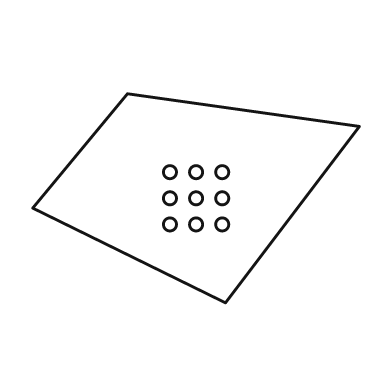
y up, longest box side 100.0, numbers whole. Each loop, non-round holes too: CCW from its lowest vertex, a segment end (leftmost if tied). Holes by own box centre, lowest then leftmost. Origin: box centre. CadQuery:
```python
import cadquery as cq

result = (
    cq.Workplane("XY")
    .moveTo(9.0, -32.0)
    .lineTo(50.0, 22.0)
    .lineTo(-21.0, 32.0)
    .lineTo(-50.0, -3.0)
    .close()
    .moveTo(-8.0, -8.0)
    .circle(2.0)
    .moveTo(0.0, -8.0)
    .circle(2.0)
    .moveTo(8.0, -8.0)
    .circle(2.0)
    .moveTo(-8.0, 0.0)
    .circle(2.0)
    .moveTo(0.0, 0.0)
    .circle(2.0)
    .moveTo(8.0, 0.0)
    .circle(2.0)
    .moveTo(-8.0, 8.0)
    .circle(2.0)
    .moveTo(0.0, 8.0)
    .circle(2.0)
    .moveTo(8.0, 8.0)
    .circle(2.0)
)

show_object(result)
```